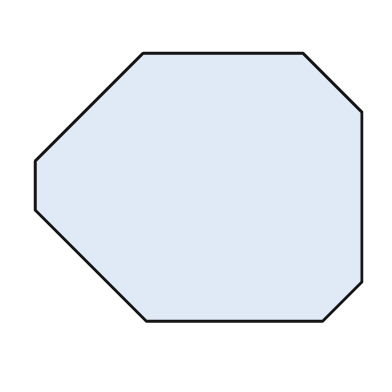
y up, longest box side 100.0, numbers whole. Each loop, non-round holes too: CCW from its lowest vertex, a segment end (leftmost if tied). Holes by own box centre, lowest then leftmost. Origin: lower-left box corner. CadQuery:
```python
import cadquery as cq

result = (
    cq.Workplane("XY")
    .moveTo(34.0, 0.0)
    .lineTo(88.0, 0.0)
    .lineTo(100.0, 12.0)
    .lineTo(100.0, 64.0)
    .lineTo(82.0, 82.0)
    .lineTo(33.0, 82.0)
    .lineTo(0.0, 49.0)
    .lineTo(0.0, 34.0)
    .close()
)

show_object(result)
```